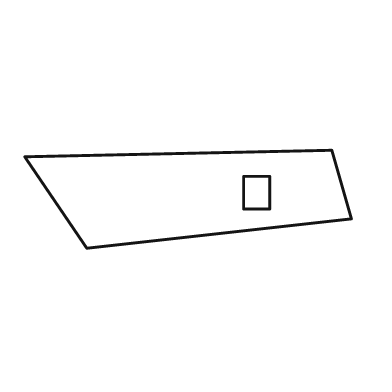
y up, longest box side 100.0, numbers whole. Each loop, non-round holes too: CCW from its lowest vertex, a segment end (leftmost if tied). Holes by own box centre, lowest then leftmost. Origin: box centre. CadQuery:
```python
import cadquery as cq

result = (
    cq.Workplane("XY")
    .moveTo(-31.0, -15.0)
    .lineTo(50.0, -6.0)
    .lineTo(44.0, 15.0)
    .lineTo(-50.0, 13.0)
    .close()
    .moveTo(17.0, -3.0)
    .lineTo(25.0, -3.0)
    .lineTo(25.0, 7.0)
    .lineTo(17.0, 7.0)
    .close()
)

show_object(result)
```